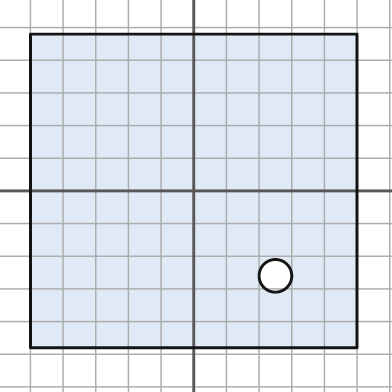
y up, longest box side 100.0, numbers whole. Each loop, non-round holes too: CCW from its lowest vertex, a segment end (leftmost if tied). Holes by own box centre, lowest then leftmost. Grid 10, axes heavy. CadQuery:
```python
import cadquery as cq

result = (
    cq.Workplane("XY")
    .moveTo(-50.0, -48.0)
    .lineTo(50.0, -48.0)
    .lineTo(50.0, 48.0)
    .lineTo(-50.0, 48.0)
    .close()
    .moveTo(25.0, -26.0)
    .circle(5.0)
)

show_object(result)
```